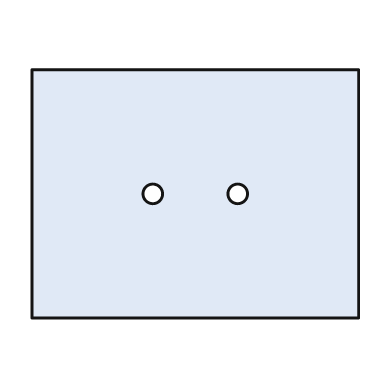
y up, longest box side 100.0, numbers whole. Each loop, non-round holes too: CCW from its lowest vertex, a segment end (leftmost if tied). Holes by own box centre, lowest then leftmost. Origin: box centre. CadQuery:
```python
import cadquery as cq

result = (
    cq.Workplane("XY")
    .moveTo(-50.0, -38.0)
    .lineTo(50.0, -38.0)
    .lineTo(50.0, 38.0)
    .lineTo(-50.0, 38.0)
    .close()
    .moveTo(-13.0, 0.0)
    .circle(3.0)
    .moveTo(13.0, 0.0)
    .circle(3.0)
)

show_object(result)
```